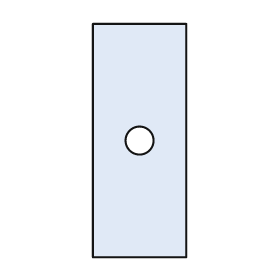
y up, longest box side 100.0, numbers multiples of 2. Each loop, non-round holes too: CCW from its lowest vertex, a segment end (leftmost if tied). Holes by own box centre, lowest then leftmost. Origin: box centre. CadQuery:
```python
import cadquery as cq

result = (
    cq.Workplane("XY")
    .moveTo(-20.0, -50.0)
    .lineTo(20.0, -50.0)
    .lineTo(20.0, 50.0)
    .lineTo(-20.0, 50.0)
    .close()
    .moveTo(0.0, 0.0)
    .circle(6.0)
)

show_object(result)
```